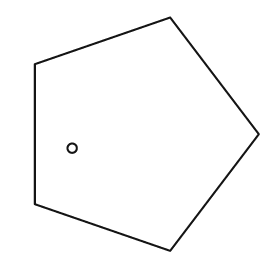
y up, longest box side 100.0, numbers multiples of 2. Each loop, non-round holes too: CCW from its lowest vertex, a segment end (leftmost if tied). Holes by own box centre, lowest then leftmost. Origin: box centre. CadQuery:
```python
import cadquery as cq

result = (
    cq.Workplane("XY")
    .moveTo(10.0, -50.0)
    .lineTo(48.0, 0.0)
    .lineTo(10.0, 50.0)
    .lineTo(-48.0, 30.0)
    .lineTo(-48.0, -30.0)
    .close()
    .moveTo(-32.0, -6.0)
    .circle(2.0)
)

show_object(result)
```